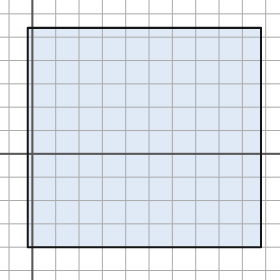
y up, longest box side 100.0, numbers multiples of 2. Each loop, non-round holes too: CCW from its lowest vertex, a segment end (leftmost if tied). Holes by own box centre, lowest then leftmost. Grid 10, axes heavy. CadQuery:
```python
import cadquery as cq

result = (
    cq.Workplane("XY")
    .moveTo(-2.0, -40.0)
    .lineTo(98.0, -40.0)
    .lineTo(98.0, 54.0)
    .lineTo(-2.0, 54.0)
    .close()
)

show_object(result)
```